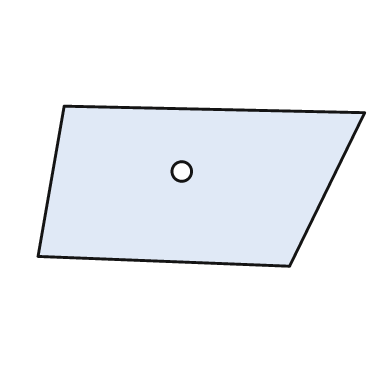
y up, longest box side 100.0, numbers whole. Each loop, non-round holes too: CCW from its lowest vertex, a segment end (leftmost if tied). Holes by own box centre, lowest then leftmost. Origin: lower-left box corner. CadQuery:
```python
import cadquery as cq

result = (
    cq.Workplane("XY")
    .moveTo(77.0, 0.0)
    .lineTo(100.0, 47.0)
    .lineTo(8.0, 49.0)
    .lineTo(0.0, 3.0)
    .close()
    .moveTo(44.0, 29.0)
    .circle(3.0)
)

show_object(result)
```